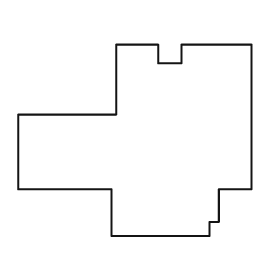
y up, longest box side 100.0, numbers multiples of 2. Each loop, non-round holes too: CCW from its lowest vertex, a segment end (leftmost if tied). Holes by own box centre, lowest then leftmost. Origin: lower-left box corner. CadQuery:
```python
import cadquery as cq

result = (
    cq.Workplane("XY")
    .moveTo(40.0, 0.0)
    .lineTo(82.0, 0.0)
    .lineTo(82.0, 6.0)
    .lineTo(86.0, 6.0)
    .lineTo(86.0, 20.0)
    .lineTo(100.0, 20.0)
    .lineTo(100.0, 82.0)
    .lineTo(70.0, 82.0)
    .lineTo(70.0, 74.0)
    .lineTo(60.0, 74.0)
    .lineTo(60.0, 82.0)
    .lineTo(42.0, 82.0)
    .lineTo(42.0, 52.0)
    .lineTo(0.0, 52.0)
    .lineTo(0.0, 20.0)
    .lineTo(40.0, 20.0)
    .close()
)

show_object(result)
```